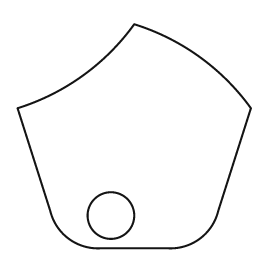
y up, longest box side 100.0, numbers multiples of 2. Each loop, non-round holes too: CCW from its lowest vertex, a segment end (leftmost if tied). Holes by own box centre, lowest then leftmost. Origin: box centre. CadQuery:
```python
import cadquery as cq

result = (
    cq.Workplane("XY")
    .moveTo(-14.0, -48.0)
    .lineTo(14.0, -48.0)
    .threePointArc((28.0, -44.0), (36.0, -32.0))
    .lineTo(50.0, 12.0)
    .threePointArc((28.0, 34.0), (0.0, 48.0))
    .threePointArc((-22.0, 26.0), (-50.0, 12.0))
    .lineTo(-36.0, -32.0)
    .threePointArc((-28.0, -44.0), (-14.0, -48.0))
    .close()
    .moveTo(-10.0, -34.0)
    .circle(10.0)
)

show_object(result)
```